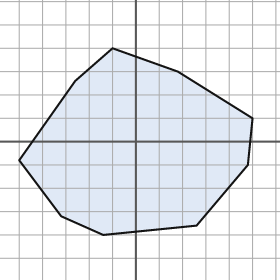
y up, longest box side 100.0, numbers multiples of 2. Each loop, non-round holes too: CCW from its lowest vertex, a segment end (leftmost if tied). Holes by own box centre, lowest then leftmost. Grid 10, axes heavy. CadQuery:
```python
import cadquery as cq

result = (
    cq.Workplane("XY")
    .moveTo(-14.0, -40.0)
    .lineTo(26.0, -36.0)
    .lineTo(48.0, -10.0)
    .lineTo(50.0, 10.0)
    .lineTo(18.0, 30.0)
    .lineTo(-10.0, 40.0)
    .lineTo(-26.0, 26.0)
    .lineTo(-50.0, -8.0)
    .lineTo(-32.0, -32.0)
    .close()
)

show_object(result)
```